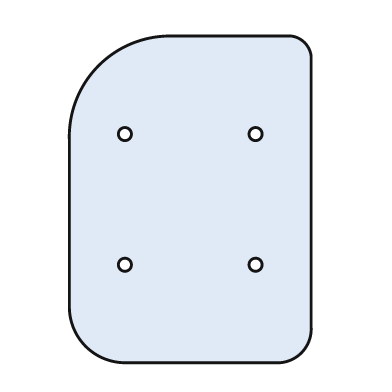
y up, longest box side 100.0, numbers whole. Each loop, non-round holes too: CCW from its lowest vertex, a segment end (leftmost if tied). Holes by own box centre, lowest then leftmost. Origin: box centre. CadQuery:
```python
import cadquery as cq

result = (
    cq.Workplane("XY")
    .moveTo(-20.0, -50.0)
    .lineTo(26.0, -50.0)
    .threePointArc((34.0, -47.0), (37.0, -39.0))
    .lineTo(37.0, 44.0)
    .threePointArc((35.0, 48.0), (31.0, 50.0))
    .lineTo(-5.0, 50.0)
    .threePointArc((-28.0, 41.0), (-37.0, 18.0))
    .lineTo(-37.0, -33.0)
    .threePointArc((-32.0, -45.0), (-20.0, -50.0))
    .close()
    .moveTo(-20.0, -20.0)
    .circle(2.0)
    .moveTo(20.0, -20.0)
    .circle(2.0)
    .moveTo(-20.0, 20.0)
    .circle(2.0)
    .moveTo(20.0, 20.0)
    .circle(2.0)
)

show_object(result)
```